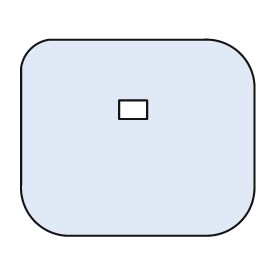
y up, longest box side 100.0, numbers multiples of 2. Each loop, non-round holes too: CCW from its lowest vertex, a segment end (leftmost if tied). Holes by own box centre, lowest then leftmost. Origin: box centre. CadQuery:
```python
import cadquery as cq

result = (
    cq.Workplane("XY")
    .moveTo(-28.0, -42.0)
    .lineTo(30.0, -42.0)
    .threePointArc((44.0, -36.0), (50.0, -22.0))
    .lineTo(50.0, 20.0)
    .threePointArc((44.0, 36.0), (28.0, 42.0))
    .lineTo(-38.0, 42.0)
    .threePointArc((-46.0, 38.0), (-50.0, 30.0))
    .lineTo(-50.0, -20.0)
    .threePointArc((-44.0, -36.0), (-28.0, -42.0))
    .close()
    .moveTo(-8.0, 8.0)
    .lineTo(4.0, 8.0)
    .lineTo(4.0, 16.0)
    .lineTo(-8.0, 16.0)
    .close()
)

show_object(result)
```